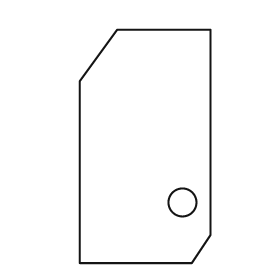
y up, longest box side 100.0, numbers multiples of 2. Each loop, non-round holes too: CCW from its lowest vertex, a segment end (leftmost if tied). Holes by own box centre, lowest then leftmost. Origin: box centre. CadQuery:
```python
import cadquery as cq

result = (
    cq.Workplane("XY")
    .moveTo(-28.0, -50.0)
    .lineTo(20.0, -50.0)
    .lineTo(28.0, -38.0)
    .lineTo(28.0, 50.0)
    .lineTo(-12.0, 50.0)
    .lineTo(-28.0, 28.0)
    .close()
    .moveTo(16.0, -24.0)
    .circle(6.0)
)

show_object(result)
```